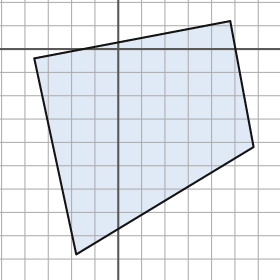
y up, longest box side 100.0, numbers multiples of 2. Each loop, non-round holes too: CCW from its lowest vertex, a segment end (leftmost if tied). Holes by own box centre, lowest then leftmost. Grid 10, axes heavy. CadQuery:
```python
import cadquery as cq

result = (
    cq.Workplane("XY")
    .moveTo(-18.0, -88.0)
    .lineTo(58.0, -42.0)
    .lineTo(48.0, 12.0)
    .lineTo(-36.0, -4.0)
    .close()
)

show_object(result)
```